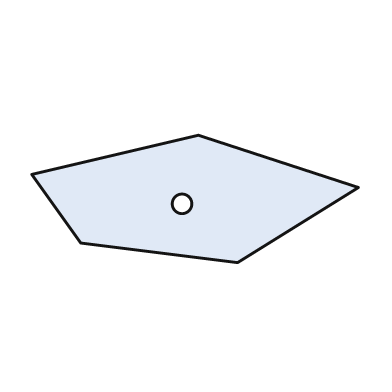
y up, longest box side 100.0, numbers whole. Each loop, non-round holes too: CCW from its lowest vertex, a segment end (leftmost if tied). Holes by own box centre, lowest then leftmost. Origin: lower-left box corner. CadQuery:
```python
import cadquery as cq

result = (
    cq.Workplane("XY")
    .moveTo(63.0, 0.0)
    .lineTo(100.0, 23.0)
    .lineTo(51.0, 39.0)
    .lineTo(0.0, 27.0)
    .lineTo(15.0, 6.0)
    .close()
    .moveTo(46.0, 18.0)
    .circle(3.0)
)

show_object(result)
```